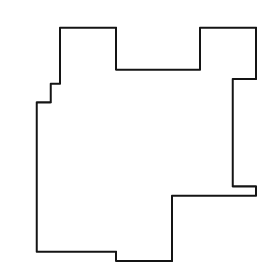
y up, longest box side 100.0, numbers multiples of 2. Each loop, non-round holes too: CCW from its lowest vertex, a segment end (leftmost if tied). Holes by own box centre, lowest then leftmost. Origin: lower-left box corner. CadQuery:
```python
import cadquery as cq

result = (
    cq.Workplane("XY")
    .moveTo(34.0, 0.0)
    .lineTo(58.0, 0.0)
    .lineTo(58.0, 28.0)
    .lineTo(94.0, 28.0)
    .lineTo(94.0, 32.0)
    .lineTo(84.0, 32.0)
    .lineTo(84.0, 78.0)
    .lineTo(94.0, 78.0)
    .lineTo(94.0, 100.0)
    .lineTo(70.0, 100.0)
    .lineTo(70.0, 82.0)
    .lineTo(34.0, 82.0)
    .lineTo(34.0, 100.0)
    .lineTo(10.0, 100.0)
    .lineTo(10.0, 76.0)
    .lineTo(6.0, 76.0)
    .lineTo(6.0, 68.0)
    .lineTo(0.0, 68.0)
    .lineTo(0.0, 4.0)
    .lineTo(34.0, 4.0)
    .close()
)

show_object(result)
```